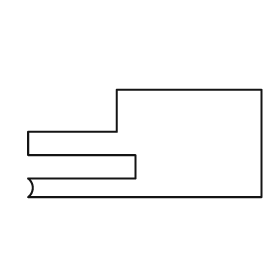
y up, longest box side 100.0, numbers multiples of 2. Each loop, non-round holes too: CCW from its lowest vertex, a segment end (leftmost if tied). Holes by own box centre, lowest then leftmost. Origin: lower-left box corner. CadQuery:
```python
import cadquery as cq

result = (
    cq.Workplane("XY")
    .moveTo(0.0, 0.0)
    .lineTo(100.0, 0.0)
    .lineTo(100.0, 46.0)
    .lineTo(38.0, 46.0)
    .lineTo(38.0, 28.0)
    .lineTo(0.0, 28.0)
    .lineTo(0.0, 18.0)
    .lineTo(46.0, 18.0)
    .lineTo(46.0, 8.0)
    .lineTo(0.0, 8.0)
    .threePointArc((2.0, 4.0), (0.0, 0.0))
    .close()
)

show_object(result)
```